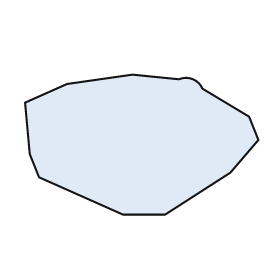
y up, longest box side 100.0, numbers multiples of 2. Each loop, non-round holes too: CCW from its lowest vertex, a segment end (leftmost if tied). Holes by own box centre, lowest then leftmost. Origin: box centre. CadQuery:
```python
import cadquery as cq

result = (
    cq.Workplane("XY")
    .moveTo(-8.0, -30.0)
    .lineTo(10.0, -30.0)
    .lineTo(38.0, -12.0)
    .lineTo(50.0, 2.0)
    .lineTo(46.0, 12.0)
    .lineTo(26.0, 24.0)
    .threePointArc((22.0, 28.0), (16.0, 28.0))
    .lineTo(-4.0, 30.0)
    .lineTo(-32.0, 26.0)
    .lineTo(-50.0, 18.0)
    .lineTo(-48.0, -4.0)
    .lineTo(-44.0, -14.0)
    .close()
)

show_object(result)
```